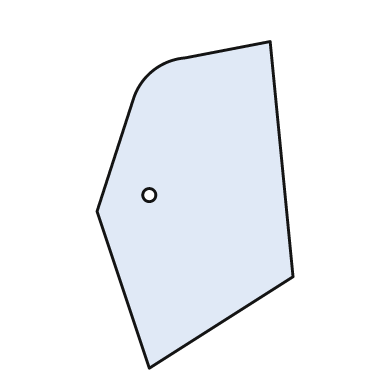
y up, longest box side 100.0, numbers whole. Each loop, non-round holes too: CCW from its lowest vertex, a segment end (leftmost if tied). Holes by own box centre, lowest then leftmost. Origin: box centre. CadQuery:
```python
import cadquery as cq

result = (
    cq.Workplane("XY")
    .moveTo(-14.0, -50.0)
    .lineTo(30.0, -22.0)
    .lineTo(23.0, 50.0)
    .lineTo(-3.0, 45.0)
    .threePointArc((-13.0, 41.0), (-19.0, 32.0))
    .lineTo(-30.0, -2.0)
    .close()
    .moveTo(-14.0, 3.0)
    .circle(2.0)
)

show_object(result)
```